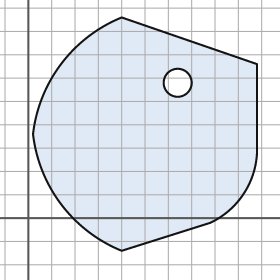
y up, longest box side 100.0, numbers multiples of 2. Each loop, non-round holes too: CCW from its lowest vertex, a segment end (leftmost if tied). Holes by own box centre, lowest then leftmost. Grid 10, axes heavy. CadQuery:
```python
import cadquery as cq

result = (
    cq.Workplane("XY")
    .moveTo(40.0, -14.0)
    .lineTo(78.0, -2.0)
    .threePointArc((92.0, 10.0), (98.0, 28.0))
    .lineTo(98.0, 66.0)
    .lineTo(40.0, 86.0)
    .threePointArc((14.0, 66.0), (2.0, 36.0))
    .threePointArc((14.0, 6.0), (40.0, -14.0))
    .close()
    .moveTo(64.0, 58.0)
    .circle(6.0)
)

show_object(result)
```